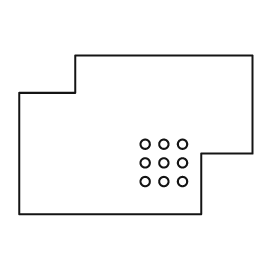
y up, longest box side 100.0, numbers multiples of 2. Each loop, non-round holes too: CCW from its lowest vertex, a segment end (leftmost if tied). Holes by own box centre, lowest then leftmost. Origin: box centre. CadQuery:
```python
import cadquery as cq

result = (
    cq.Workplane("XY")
    .moveTo(-50.0, -34.0)
    .lineTo(28.0, -34.0)
    .lineTo(28.0, -8.0)
    .lineTo(50.0, -8.0)
    .lineTo(50.0, 34.0)
    .lineTo(-26.0, 34.0)
    .lineTo(-26.0, 18.0)
    .lineTo(-50.0, 18.0)
    .close()
    .moveTo(4.0, -20.0)
    .circle(2.0)
    .moveTo(12.0, -20.0)
    .circle(2.0)
    .moveTo(20.0, -20.0)
    .circle(2.0)
    .moveTo(4.0, -12.0)
    .circle(2.0)
    .moveTo(12.0, -12.0)
    .circle(2.0)
    .moveTo(20.0, -12.0)
    .circle(2.0)
    .moveTo(4.0, -4.0)
    .circle(2.0)
    .moveTo(12.0, -4.0)
    .circle(2.0)
    .moveTo(20.0, -4.0)
    .circle(2.0)
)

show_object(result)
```